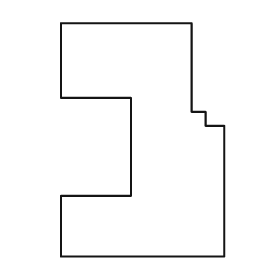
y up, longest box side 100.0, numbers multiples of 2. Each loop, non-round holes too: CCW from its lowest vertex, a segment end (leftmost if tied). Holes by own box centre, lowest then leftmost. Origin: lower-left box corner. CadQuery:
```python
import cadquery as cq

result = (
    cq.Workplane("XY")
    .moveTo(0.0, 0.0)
    .lineTo(70.0, 0.0)
    .lineTo(70.0, 56.0)
    .lineTo(62.0, 56.0)
    .lineTo(62.0, 62.0)
    .lineTo(56.0, 62.0)
    .lineTo(56.0, 100.0)
    .lineTo(0.0, 100.0)
    .lineTo(0.0, 68.0)
    .lineTo(30.0, 68.0)
    .lineTo(30.0, 26.0)
    .lineTo(0.0, 26.0)
    .close()
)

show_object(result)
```